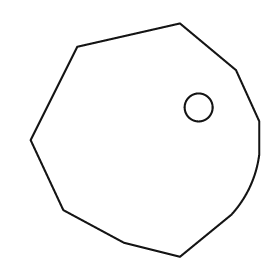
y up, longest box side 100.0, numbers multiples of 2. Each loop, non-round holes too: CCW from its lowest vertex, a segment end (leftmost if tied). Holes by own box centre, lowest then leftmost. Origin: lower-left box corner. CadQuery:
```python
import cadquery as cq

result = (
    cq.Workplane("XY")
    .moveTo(64.0, 0.0)
    .lineTo(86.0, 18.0)
    .threePointArc((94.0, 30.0), (98.0, 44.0))
    .lineTo(98.0, 58.0)
    .lineTo(88.0, 80.0)
    .lineTo(64.0, 100.0)
    .lineTo(20.0, 90.0)
    .lineTo(0.0, 50.0)
    .lineTo(14.0, 20.0)
    .lineTo(40.0, 6.0)
    .close()
    .moveTo(72.0, 64.0)
    .circle(6.0)
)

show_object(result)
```